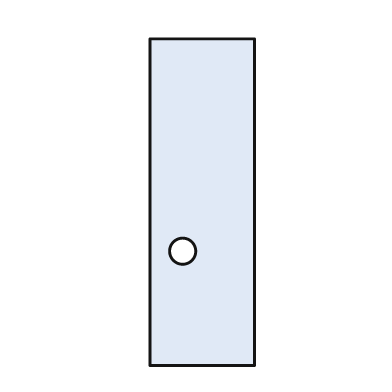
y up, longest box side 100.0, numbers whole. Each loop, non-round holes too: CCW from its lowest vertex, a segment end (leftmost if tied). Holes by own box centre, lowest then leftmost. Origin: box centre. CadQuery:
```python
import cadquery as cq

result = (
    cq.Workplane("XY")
    .moveTo(-16.0, -50.0)
    .lineTo(16.0, -50.0)
    .lineTo(16.0, 50.0)
    .lineTo(-16.0, 50.0)
    .close()
    .moveTo(-6.0, -15.0)
    .circle(4.0)
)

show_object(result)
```